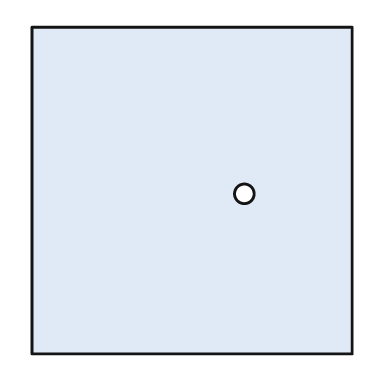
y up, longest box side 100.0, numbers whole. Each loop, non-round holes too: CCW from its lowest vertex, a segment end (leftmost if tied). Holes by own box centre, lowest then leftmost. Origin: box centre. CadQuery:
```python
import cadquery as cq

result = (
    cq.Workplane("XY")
    .moveTo(-49.0, -50.0)
    .lineTo(49.0, -50.0)
    .lineTo(49.0, 50.0)
    .lineTo(-49.0, 50.0)
    .close()
    .moveTo(16.0, -1.0)
    .circle(3.0)
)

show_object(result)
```